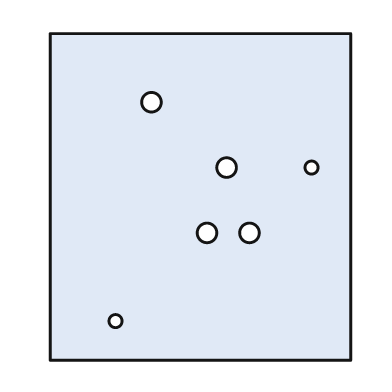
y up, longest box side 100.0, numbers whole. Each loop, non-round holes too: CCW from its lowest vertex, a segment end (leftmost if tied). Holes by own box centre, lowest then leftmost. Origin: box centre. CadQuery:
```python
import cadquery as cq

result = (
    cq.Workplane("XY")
    .moveTo(-46.0, -50.0)
    .lineTo(46.0, -50.0)
    .lineTo(46.0, 50.0)
    .lineTo(-46.0, 50.0)
    .close()
    .moveTo(-26.0, -38.0)
    .circle(2.0)
    .moveTo(2.0, -11.0)
    .circle(3.0)
    .moveTo(15.0, -11.0)
    .circle(3.0)
    .moveTo(8.0, 9.0)
    .circle(3.0)
    .moveTo(34.0, 9.0)
    .circle(2.0)
    .moveTo(-15.0, 29.0)
    .circle(3.0)
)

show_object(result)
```